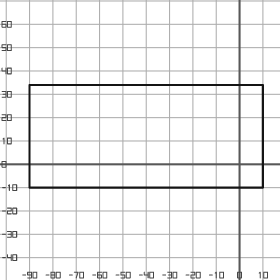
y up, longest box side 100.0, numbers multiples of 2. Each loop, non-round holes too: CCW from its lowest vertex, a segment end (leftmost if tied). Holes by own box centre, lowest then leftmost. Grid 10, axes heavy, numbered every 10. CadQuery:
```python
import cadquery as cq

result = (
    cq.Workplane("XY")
    .moveTo(-90.0, -10.0)
    .lineTo(10.0, -10.0)
    .lineTo(10.0, 34.0)
    .lineTo(-90.0, 34.0)
    .close()
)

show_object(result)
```